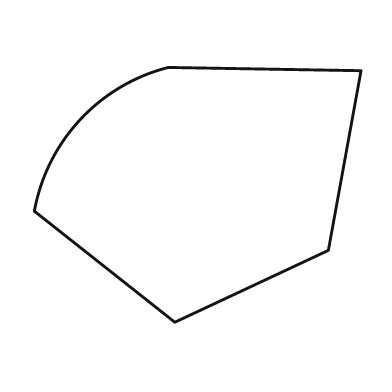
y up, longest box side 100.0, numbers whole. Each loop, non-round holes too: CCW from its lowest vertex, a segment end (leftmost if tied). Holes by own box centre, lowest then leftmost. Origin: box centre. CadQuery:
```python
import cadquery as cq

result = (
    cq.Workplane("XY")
    .moveTo(-7.0, -39.0)
    .lineTo(40.0, -17.0)
    .lineTo(50.0, 38.0)
    .lineTo(-9.0, 39.0)
    .threePointArc((-36.0, 23.0), (-50.0, -5.0))
    .close()
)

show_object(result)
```